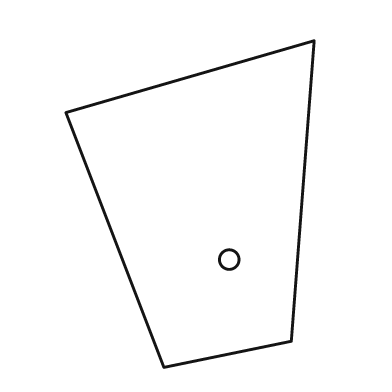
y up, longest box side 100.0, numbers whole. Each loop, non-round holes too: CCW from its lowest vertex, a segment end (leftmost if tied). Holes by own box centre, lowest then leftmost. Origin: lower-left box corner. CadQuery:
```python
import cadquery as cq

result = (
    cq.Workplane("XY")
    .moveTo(30.0, 0.0)
    .lineTo(69.0, 8.0)
    .lineTo(76.0, 100.0)
    .lineTo(0.0, 78.0)
    .close()
    .moveTo(50.0, 33.0)
    .circle(3.0)
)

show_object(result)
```